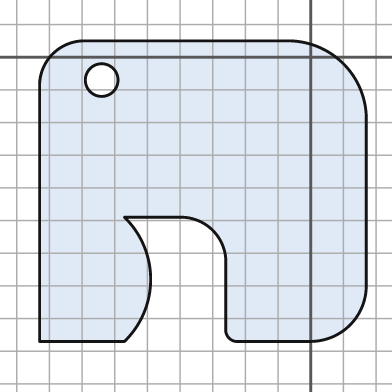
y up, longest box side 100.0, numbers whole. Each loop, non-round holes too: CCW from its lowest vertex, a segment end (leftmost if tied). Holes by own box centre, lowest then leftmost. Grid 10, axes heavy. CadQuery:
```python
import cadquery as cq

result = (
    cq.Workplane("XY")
    .moveTo(-83.0, -87.0)
    .lineTo(-57.0, -87.0)
    .threePointArc((-49.0, -68.0), (-57.0, -49.0))
    .lineTo(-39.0, -49.0)
    .threePointArc((-30.0, -53.0), (-26.0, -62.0))
    .lineTo(-26.0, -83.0)
    .threePointArc((-25.0, -86.0), (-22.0, -87.0))
    .lineTo(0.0, -87.0)
    .threePointArc((12.0, -82.0), (17.0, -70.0))
    .lineTo(17.0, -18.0)
    .threePointArc((10.0, -2.0), (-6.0, 5.0))
    .lineTo(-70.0, 5.0)
    .threePointArc((-79.0, 1.0), (-83.0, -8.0))
    .close()
    .moveTo(-64.0, -7.0)
    .circle(5.0)
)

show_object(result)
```